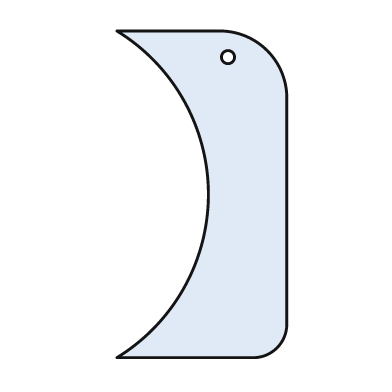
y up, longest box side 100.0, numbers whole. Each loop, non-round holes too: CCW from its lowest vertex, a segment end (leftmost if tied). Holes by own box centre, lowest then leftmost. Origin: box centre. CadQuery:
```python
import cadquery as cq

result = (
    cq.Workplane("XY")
    .moveTo(-26.0, -50.0)
    .lineTo(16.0, -50.0)
    .threePointArc((23.0, -47.0), (26.0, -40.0))
    .lineTo(26.0, 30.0)
    .threePointArc((20.0, 44.0), (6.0, 50.0))
    .lineTo(-26.0, 50.0)
    .threePointArc((2.0, 0.0), (-26.0, -50.0))
    .close()
    .moveTo(8.0, 42.0)
    .circle(2.0)
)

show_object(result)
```